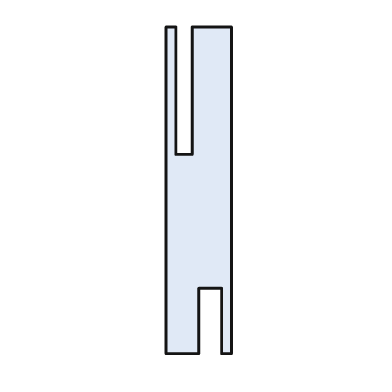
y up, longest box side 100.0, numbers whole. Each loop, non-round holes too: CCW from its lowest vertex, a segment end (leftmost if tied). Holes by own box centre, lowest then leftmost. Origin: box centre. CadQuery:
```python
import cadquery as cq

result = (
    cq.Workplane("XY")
    .moveTo(-10.0, -50.0)
    .lineTo(0.0, -50.0)
    .lineTo(0.0, -30.0)
    .lineTo(7.0, -30.0)
    .lineTo(7.0, -50.0)
    .lineTo(10.0, -50.0)
    .lineTo(10.0, 50.0)
    .lineTo(-2.0, 50.0)
    .lineTo(-2.0, 11.0)
    .lineTo(-7.0, 11.0)
    .lineTo(-7.0, 50.0)
    .lineTo(-10.0, 50.0)
    .close()
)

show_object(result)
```